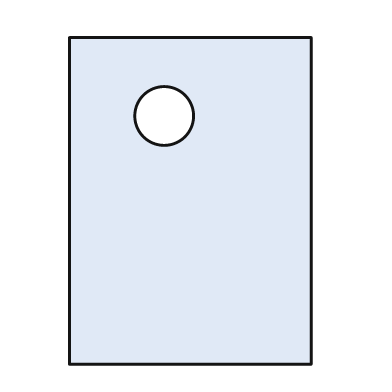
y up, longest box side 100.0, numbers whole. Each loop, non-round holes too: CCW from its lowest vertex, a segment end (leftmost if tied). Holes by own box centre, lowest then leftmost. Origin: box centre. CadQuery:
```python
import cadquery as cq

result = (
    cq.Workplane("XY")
    .moveTo(-37.0, -50.0)
    .lineTo(37.0, -50.0)
    .lineTo(37.0, 50.0)
    .lineTo(-37.0, 50.0)
    .close()
    .moveTo(-8.0, 26.0)
    .circle(9.0)
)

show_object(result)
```